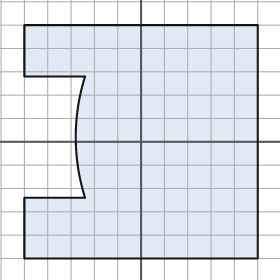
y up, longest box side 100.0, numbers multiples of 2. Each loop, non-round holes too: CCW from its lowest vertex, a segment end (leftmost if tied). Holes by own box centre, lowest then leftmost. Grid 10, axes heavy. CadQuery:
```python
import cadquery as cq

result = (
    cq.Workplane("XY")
    .moveTo(-50.0, -50.0)
    .lineTo(50.0, -50.0)
    .lineTo(50.0, 50.0)
    .lineTo(-50.0, 50.0)
    .lineTo(-50.0, 28.0)
    .lineTo(-24.0, 28.0)
    .threePointArc((-28.0, 2.0), (-24.0, -24.0))
    .lineTo(-50.0, -24.0)
    .close()
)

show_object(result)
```